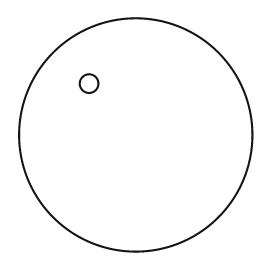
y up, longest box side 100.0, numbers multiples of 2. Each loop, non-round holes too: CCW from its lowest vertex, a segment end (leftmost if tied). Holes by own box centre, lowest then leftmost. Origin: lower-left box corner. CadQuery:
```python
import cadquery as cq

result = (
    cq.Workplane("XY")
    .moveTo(50.0, 50.0)
    .circle(50.0)
    .moveTo(30.0, 72.0)
    .circle(4.0)
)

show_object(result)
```